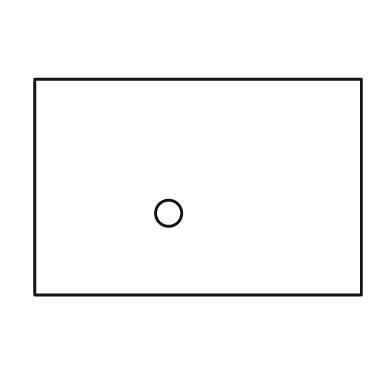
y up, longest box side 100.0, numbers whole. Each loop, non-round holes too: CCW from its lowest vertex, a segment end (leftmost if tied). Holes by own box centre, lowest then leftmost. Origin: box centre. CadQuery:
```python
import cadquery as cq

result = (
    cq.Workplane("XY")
    .moveTo(-50.0, -33.0)
    .lineTo(50.0, -33.0)
    .lineTo(50.0, 33.0)
    .lineTo(-50.0, 33.0)
    .close()
    .moveTo(-9.0, -8.0)
    .circle(4.0)
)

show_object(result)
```